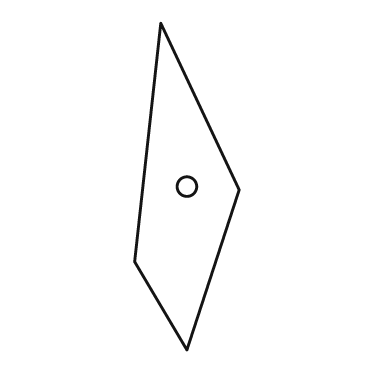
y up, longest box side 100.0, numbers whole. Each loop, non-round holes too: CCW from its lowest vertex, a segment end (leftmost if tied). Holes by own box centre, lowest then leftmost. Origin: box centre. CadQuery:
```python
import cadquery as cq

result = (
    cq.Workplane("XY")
    .moveTo(0.0, -50.0)
    .lineTo(16.0, -1.0)
    .lineTo(-8.0, 50.0)
    .lineTo(-16.0, -23.0)
    .close()
    .moveTo(0.0, 0.0)
    .circle(3.0)
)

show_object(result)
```